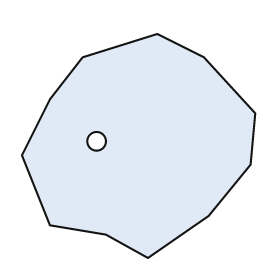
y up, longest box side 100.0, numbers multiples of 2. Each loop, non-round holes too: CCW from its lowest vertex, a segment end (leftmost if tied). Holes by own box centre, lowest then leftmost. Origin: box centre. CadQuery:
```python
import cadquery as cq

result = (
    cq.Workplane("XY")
    .moveTo(4.0, -48.0)
    .lineTo(30.0, -30.0)
    .lineTo(48.0, -8.0)
    .lineTo(50.0, 14.0)
    .lineTo(28.0, 38.0)
    .lineTo(8.0, 48.0)
    .lineTo(-24.0, 38.0)
    .lineTo(-38.0, 20.0)
    .lineTo(-50.0, -4.0)
    .lineTo(-38.0, -34.0)
    .lineTo(-14.0, -38.0)
    .close()
    .moveTo(-18.0, 2.0)
    .circle(4.0)
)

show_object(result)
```